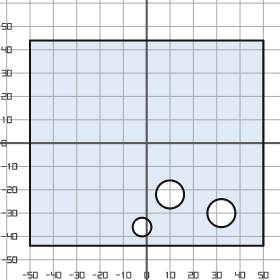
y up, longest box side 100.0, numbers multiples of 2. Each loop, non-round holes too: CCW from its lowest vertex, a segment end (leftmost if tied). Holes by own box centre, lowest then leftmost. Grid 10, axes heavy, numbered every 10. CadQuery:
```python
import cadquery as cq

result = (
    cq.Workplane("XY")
    .moveTo(-50.0, -44.0)
    .lineTo(50.0, -44.0)
    .lineTo(50.0, 44.0)
    .lineTo(-50.0, 44.0)
    .close()
    .moveTo(-2.0, -36.0)
    .circle(4.0)
    .moveTo(32.0, -30.0)
    .circle(6.0)
    .moveTo(10.0, -22.0)
    .circle(6.0)
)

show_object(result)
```